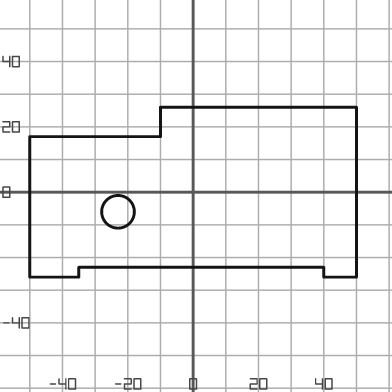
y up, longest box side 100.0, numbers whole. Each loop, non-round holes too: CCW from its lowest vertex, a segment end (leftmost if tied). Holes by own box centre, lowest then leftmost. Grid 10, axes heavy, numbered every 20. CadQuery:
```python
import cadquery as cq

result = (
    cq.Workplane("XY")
    .moveTo(-50.0, -26.0)
    .lineTo(-35.0, -26.0)
    .lineTo(-35.0, -23.0)
    .lineTo(40.0, -23.0)
    .lineTo(40.0, -26.0)
    .lineTo(50.0, -26.0)
    .lineTo(50.0, 26.0)
    .lineTo(-10.0, 26.0)
    .lineTo(-10.0, 17.0)
    .lineTo(-50.0, 17.0)
    .close()
    .moveTo(-23.0, -6.0)
    .circle(5.0)
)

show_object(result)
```